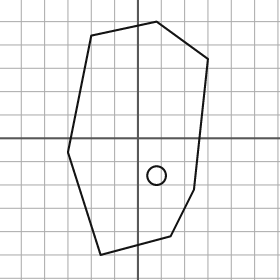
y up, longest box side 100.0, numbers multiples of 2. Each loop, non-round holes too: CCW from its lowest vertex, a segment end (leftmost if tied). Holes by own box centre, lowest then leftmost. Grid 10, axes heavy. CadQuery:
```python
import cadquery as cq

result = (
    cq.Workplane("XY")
    .moveTo(-16.0, -50.0)
    .lineTo(14.0, -42.0)
    .lineTo(24.0, -22.0)
    .lineTo(30.0, 34.0)
    .lineTo(8.0, 50.0)
    .lineTo(-20.0, 44.0)
    .lineTo(-30.0, -6.0)
    .close()
    .moveTo(8.0, -16.0)
    .circle(4.0)
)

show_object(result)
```